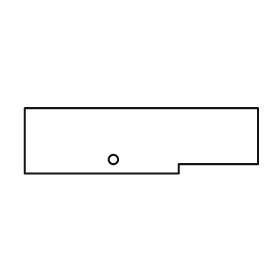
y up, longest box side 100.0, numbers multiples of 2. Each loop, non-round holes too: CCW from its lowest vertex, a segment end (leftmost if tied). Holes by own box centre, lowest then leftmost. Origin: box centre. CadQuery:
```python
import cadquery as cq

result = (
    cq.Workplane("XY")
    .moveTo(-50.0, -14.0)
    .lineTo(16.0, -14.0)
    .lineTo(16.0, -10.0)
    .lineTo(50.0, -10.0)
    .lineTo(50.0, 14.0)
    .lineTo(-50.0, 14.0)
    .close()
    .moveTo(-12.0, -8.0)
    .circle(2.0)
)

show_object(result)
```